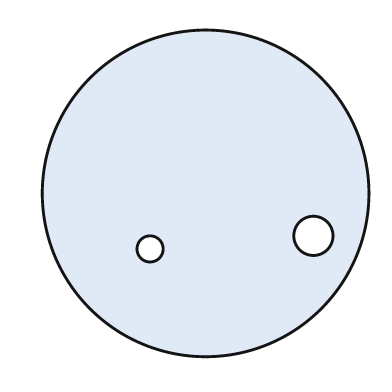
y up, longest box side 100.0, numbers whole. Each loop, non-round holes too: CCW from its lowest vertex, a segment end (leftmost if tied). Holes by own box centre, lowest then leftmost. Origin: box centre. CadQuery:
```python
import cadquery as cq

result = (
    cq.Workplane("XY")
    .moveTo(0.0, 0.0)
    .circle(50.0)
    .moveTo(-17.0, -17.0)
    .circle(4.0)
    .moveTo(33.0, -13.0)
    .circle(6.0)
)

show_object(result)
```